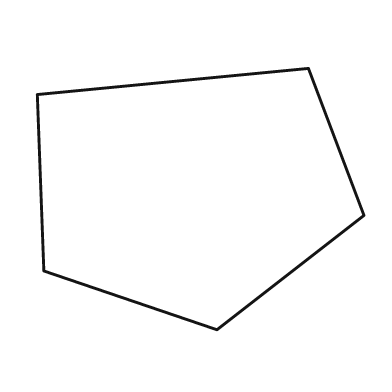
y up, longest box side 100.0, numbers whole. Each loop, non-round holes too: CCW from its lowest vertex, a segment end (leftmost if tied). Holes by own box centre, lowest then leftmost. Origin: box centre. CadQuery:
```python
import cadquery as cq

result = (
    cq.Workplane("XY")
    .moveTo(5.0, -40.0)
    .lineTo(50.0, -5.0)
    .lineTo(33.0, 40.0)
    .lineTo(-50.0, 32.0)
    .lineTo(-48.0, -22.0)
    .close()
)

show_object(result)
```